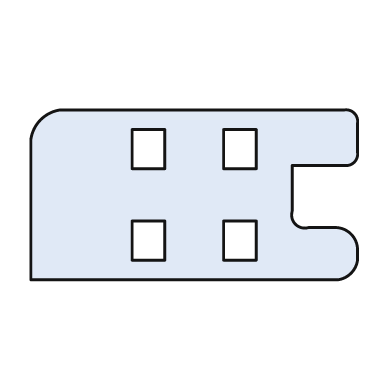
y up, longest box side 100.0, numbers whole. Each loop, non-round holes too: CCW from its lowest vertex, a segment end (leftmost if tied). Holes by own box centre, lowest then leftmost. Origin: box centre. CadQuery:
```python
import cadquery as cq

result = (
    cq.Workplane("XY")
    .moveTo(-50.0, -26.0)
    .lineTo(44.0, -26.0)
    .threePointArc((48.0, -24.0), (50.0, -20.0))
    .lineTo(50.0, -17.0)
    .threePointArc((48.0, -12.0), (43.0, -10.0))
    .lineTo(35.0, -10.0)
    .threePointArc((31.0, -9.0), (30.0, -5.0))
    .lineTo(30.0, 9.0)
    .lineTo(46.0, 9.0)
    .threePointArc((49.0, 10.0), (50.0, 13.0))
    .lineTo(50.0, 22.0)
    .threePointArc((49.0, 25.0), (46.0, 26.0))
    .lineTo(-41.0, 26.0)
    .threePointArc((-47.0, 23.0), (-50.0, 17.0))
    .close()
    .moveTo(-19.0, -20.0)
    .lineTo(-9.0, -20.0)
    .lineTo(-9.0, -8.0)
    .lineTo(-19.0, -8.0)
    .close()
    .moveTo(9.0, -20.0)
    .lineTo(19.0, -20.0)
    .lineTo(19.0, -8.0)
    .lineTo(9.0, -8.0)
    .close()
    .moveTo(-19.0, 8.0)
    .lineTo(-9.0, 8.0)
    .lineTo(-9.0, 20.0)
    .lineTo(-19.0, 20.0)
    .close()
    .moveTo(9.0, 8.0)
    .lineTo(19.0, 8.0)
    .lineTo(19.0, 20.0)
    .lineTo(9.0, 20.0)
    .close()
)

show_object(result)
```